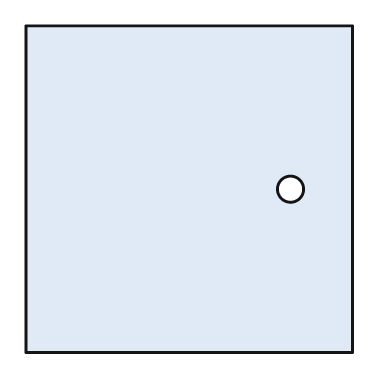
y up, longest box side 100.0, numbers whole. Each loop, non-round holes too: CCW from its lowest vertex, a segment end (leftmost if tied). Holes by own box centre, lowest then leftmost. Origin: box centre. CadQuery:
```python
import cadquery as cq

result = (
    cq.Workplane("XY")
    .moveTo(-50.0, -50.0)
    .lineTo(50.0, -50.0)
    .lineTo(50.0, 50.0)
    .lineTo(-50.0, 50.0)
    .close()
    .moveTo(31.0, 0.0)
    .circle(4.0)
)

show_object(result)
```